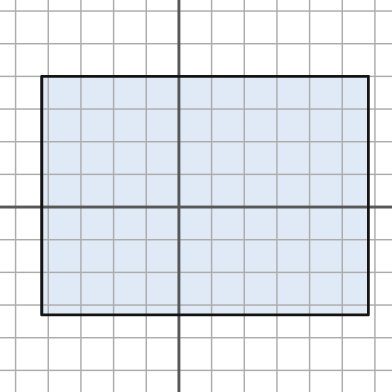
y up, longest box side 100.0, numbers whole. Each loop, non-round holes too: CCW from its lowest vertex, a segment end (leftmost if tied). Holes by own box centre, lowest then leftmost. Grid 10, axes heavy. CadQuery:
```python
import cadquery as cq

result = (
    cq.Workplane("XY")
    .moveTo(-42.0, -33.0)
    .lineTo(58.0, -33.0)
    .lineTo(58.0, 40.0)
    .lineTo(-42.0, 40.0)
    .close()
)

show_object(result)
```